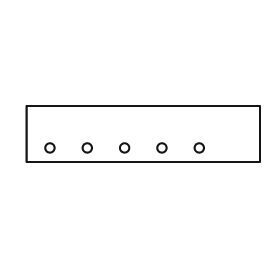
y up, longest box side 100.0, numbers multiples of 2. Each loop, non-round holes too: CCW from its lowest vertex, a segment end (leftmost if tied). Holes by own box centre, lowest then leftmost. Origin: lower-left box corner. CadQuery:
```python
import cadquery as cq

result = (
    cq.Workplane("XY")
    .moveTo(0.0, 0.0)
    .lineTo(100.0, 0.0)
    .lineTo(100.0, 24.0)
    .lineTo(0.0, 24.0)
    .close()
    .moveTo(10.0, 6.0)
    .circle(2.0)
    .moveTo(26.0, 6.0)
    .circle(2.0)
    .moveTo(42.0, 6.0)
    .circle(2.0)
    .moveTo(58.0, 6.0)
    .circle(2.0)
    .moveTo(74.0, 6.0)
    .circle(2.0)
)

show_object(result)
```